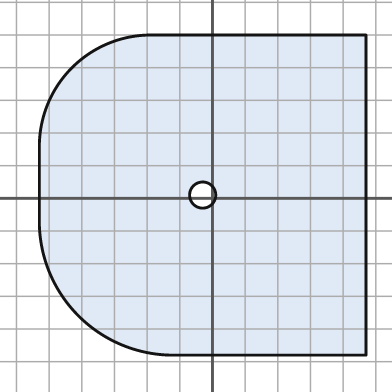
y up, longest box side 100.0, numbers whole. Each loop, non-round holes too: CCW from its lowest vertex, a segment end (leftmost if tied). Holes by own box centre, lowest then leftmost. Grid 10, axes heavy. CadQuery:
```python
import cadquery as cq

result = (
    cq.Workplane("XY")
    .moveTo(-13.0, -48.0)
    .lineTo(47.0, -48.0)
    .lineTo(47.0, 50.0)
    .lineTo(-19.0, 50.0)
    .threePointArc((-43.0, 40.0), (-53.0, 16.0))
    .lineTo(-53.0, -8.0)
    .threePointArc((-41.0, -36.0), (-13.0, -48.0))
    .close()
    .moveTo(-3.0, 1.0)
    .circle(4.0)
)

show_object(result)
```